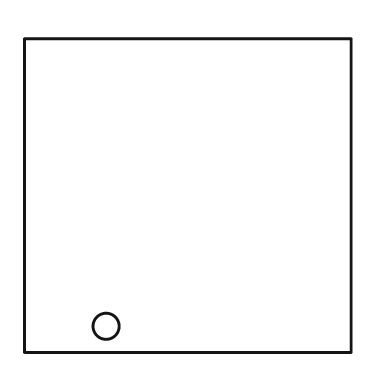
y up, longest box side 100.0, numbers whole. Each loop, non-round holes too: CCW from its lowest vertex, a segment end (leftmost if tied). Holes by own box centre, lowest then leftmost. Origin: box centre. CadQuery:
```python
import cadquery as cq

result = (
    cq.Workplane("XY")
    .moveTo(-50.0, -48.0)
    .lineTo(50.0, -48.0)
    .lineTo(50.0, 48.0)
    .lineTo(-50.0, 48.0)
    .close()
    .moveTo(-25.0, -40.0)
    .circle(4.0)
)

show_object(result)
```